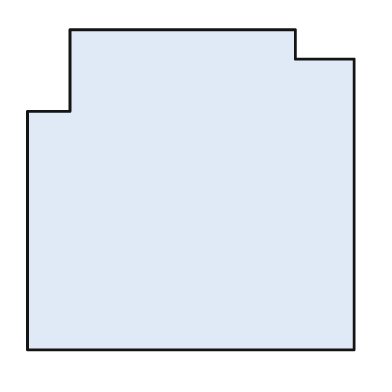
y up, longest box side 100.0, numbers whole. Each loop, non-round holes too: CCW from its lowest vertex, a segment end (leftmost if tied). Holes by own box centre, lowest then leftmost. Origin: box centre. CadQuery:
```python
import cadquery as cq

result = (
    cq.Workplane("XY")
    .moveTo(-50.0, -49.0)
    .lineTo(50.0, -49.0)
    .lineTo(50.0, 40.0)
    .lineTo(32.0, 40.0)
    .lineTo(32.0, 49.0)
    .lineTo(-37.0, 49.0)
    .lineTo(-37.0, 24.0)
    .lineTo(-50.0, 24.0)
    .close()
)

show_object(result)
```